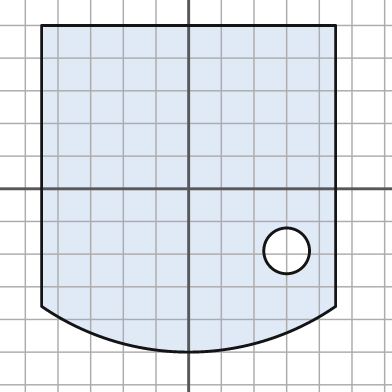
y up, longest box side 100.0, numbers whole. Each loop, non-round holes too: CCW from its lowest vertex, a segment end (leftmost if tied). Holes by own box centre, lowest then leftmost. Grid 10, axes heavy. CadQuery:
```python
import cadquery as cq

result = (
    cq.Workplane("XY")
    .moveTo(-45.0, -36.0)
    .threePointArc((0.0, -50.0), (45.0, -36.0))
    .lineTo(45.0, 50.0)
    .lineTo(-45.0, 50.0)
    .close()
    .moveTo(30.0, -19.0)
    .circle(7.0)
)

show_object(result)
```